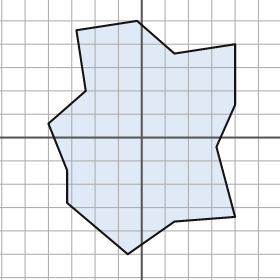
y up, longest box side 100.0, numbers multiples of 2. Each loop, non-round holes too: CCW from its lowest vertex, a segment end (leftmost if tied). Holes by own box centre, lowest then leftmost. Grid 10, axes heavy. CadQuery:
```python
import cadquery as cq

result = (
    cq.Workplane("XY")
    .moveTo(-6.0, -50.0)
    .lineTo(14.0, -36.0)
    .lineTo(40.0, -34.0)
    .lineTo(32.0, -4.0)
    .lineTo(40.0, 14.0)
    .lineTo(40.0, 40.0)
    .lineTo(14.0, 36.0)
    .lineTo(-2.0, 50.0)
    .lineTo(-28.0, 46.0)
    .lineTo(-24.0, 20.0)
    .lineTo(-40.0, 6.0)
    .lineTo(-32.0, -14.0)
    .lineTo(-32.0, -28.0)
    .close()
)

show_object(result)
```